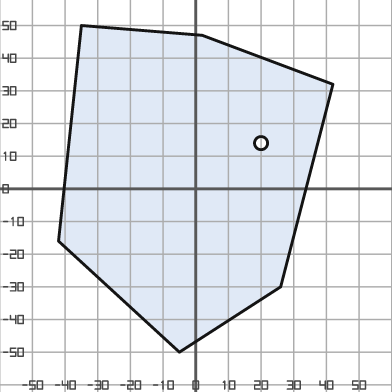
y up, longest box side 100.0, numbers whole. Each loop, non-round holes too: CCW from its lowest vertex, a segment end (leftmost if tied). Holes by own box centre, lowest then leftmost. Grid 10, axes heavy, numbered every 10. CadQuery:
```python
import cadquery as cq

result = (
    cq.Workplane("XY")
    .moveTo(-5.0, -50.0)
    .lineTo(26.0, -30.0)
    .lineTo(42.0, 32.0)
    .lineTo(2.0, 47.0)
    .lineTo(-35.0, 50.0)
    .lineTo(-42.0, -16.0)
    .close()
    .moveTo(20.0, 14.0)
    .circle(2.0)
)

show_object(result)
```